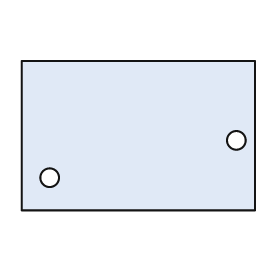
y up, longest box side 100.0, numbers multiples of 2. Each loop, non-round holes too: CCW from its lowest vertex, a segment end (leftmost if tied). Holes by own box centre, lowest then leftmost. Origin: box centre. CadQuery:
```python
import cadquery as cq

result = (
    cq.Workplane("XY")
    .moveTo(-50.0, -32.0)
    .lineTo(50.0, -32.0)
    .lineTo(50.0, 32.0)
    .lineTo(-50.0, 32.0)
    .close()
    .moveTo(-38.0, -18.0)
    .circle(4.0)
    .moveTo(42.0, -2.0)
    .circle(4.0)
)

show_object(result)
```